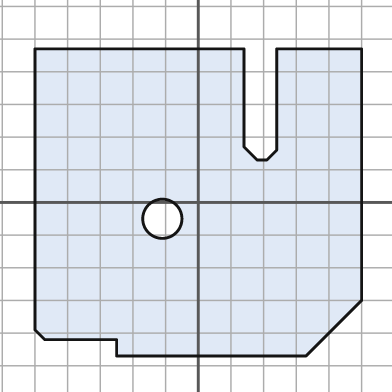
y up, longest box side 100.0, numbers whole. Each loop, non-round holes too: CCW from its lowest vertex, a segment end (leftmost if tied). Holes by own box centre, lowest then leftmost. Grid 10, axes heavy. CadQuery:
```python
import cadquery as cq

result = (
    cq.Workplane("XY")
    .moveTo(-25.0, -47.0)
    .lineTo(33.0, -47.0)
    .lineTo(50.0, -30.0)
    .lineTo(50.0, 47.0)
    .lineTo(24.0, 47.0)
    .lineTo(24.0, 16.0)
    .lineTo(21.0, 13.0)
    .lineTo(18.0, 13.0)
    .lineTo(14.0, 17.0)
    .lineTo(14.0, 47.0)
    .lineTo(-50.0, 47.0)
    .lineTo(-50.0, -39.0)
    .lineTo(-47.0, -42.0)
    .lineTo(-25.0, -42.0)
    .close()
    .moveTo(-11.0, -5.0)
    .circle(6.0)
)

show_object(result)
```